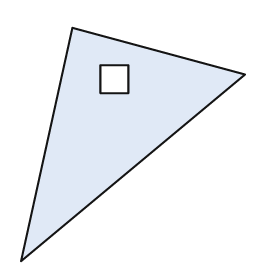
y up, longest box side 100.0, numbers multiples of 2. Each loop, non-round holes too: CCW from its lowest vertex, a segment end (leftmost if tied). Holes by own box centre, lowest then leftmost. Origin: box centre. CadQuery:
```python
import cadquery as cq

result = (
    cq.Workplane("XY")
    .moveTo(-48.0, -50.0)
    .lineTo(48.0, 30.0)
    .lineTo(-26.0, 50.0)
    .close()
    .moveTo(-14.0, 22.0)
    .lineTo(-2.0, 22.0)
    .lineTo(-2.0, 34.0)
    .lineTo(-14.0, 34.0)
    .close()
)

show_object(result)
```